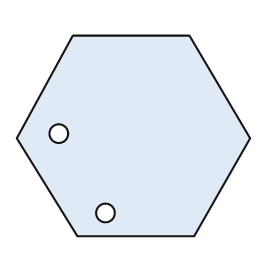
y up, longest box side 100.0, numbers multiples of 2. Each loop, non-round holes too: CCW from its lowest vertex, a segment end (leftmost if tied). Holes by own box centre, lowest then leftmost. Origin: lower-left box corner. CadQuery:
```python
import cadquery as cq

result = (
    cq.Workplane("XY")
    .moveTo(26.0, 0.0)
    .lineTo(76.0, 0.0)
    .lineTo(100.0, 42.0)
    .lineTo(74.0, 86.0)
    .lineTo(24.0, 86.0)
    .lineTo(0.0, 42.0)
    .close()
    .moveTo(38.0, 10.0)
    .circle(4.0)
    .moveTo(18.0, 44.0)
    .circle(4.0)
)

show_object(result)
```